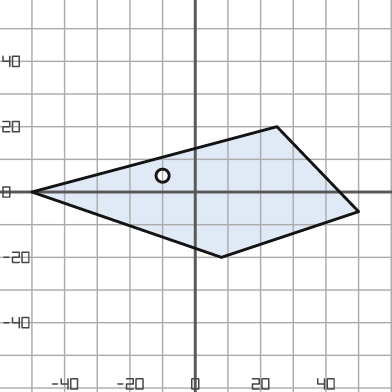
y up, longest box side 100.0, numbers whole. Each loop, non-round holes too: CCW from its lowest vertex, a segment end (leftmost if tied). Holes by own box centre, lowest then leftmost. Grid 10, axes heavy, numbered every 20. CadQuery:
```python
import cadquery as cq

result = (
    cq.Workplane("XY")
    .moveTo(8.0, -20.0)
    .lineTo(50.0, -6.0)
    .lineTo(25.0, 20.0)
    .lineTo(-50.0, 0.0)
    .close()
    .moveTo(-10.0, 5.0)
    .circle(2.0)
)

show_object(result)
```